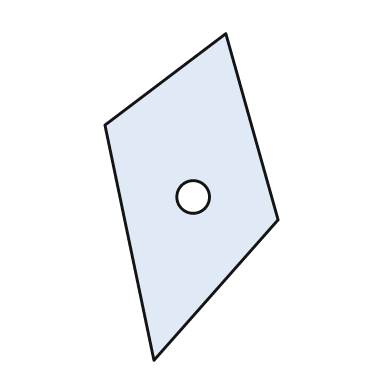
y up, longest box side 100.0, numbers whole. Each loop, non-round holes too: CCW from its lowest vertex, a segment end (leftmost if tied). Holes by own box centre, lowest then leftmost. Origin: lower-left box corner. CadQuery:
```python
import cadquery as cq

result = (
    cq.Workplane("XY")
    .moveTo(15.0, 0.0)
    .lineTo(53.0, 43.0)
    .lineTo(37.0, 100.0)
    .lineTo(0.0, 72.0)
    .close()
    .moveTo(27.0, 50.0)
    .circle(5.0)
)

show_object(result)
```